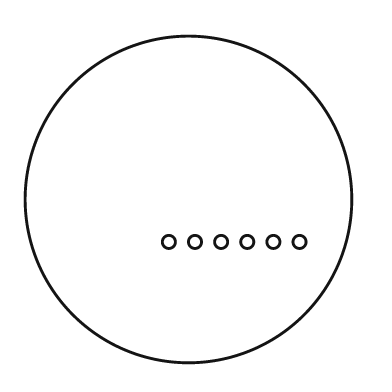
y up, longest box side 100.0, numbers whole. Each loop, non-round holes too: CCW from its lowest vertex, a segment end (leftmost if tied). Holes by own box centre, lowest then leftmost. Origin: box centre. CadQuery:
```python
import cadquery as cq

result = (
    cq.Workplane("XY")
    .moveTo(0.0, 0.0)
    .circle(50.0)
    .moveTo(-6.0, -13.0)
    .circle(2.0)
    .moveTo(2.0, -13.0)
    .circle(2.0)
    .moveTo(10.0, -13.0)
    .circle(2.0)
    .moveTo(18.0, -13.0)
    .circle(2.0)
    .moveTo(26.0, -13.0)
    .circle(2.0)
    .moveTo(34.0, -13.0)
    .circle(2.0)
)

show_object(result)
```